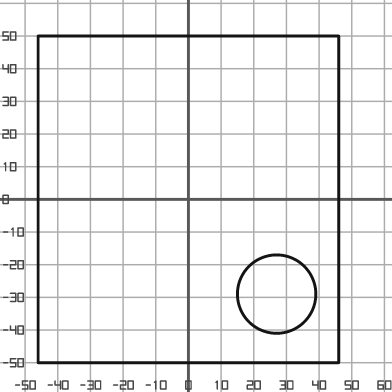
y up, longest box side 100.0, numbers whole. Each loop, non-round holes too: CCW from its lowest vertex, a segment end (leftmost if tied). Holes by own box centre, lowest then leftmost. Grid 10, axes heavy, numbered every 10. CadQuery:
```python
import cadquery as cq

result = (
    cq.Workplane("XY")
    .moveTo(-46.0, -50.0)
    .lineTo(46.0, -50.0)
    .lineTo(46.0, 50.0)
    .lineTo(-46.0, 50.0)
    .close()
    .moveTo(27.0, -29.0)
    .circle(12.0)
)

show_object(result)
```